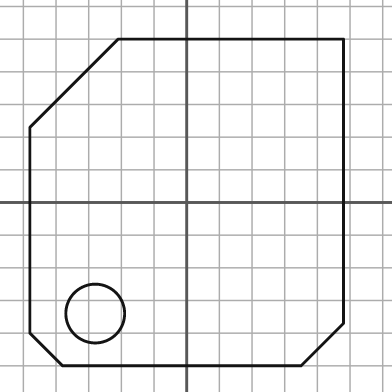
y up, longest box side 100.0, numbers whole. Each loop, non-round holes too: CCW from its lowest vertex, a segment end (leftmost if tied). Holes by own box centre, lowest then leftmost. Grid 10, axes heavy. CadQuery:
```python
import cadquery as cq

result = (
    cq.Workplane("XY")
    .moveTo(-38.0, -50.0)
    .lineTo(35.0, -50.0)
    .lineTo(48.0, -37.0)
    .lineTo(48.0, 50.0)
    .lineTo(-21.0, 50.0)
    .lineTo(-48.0, 23.0)
    .lineTo(-48.0, -40.0)
    .close()
    .moveTo(-28.0, -34.0)
    .circle(9.0)
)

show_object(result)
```